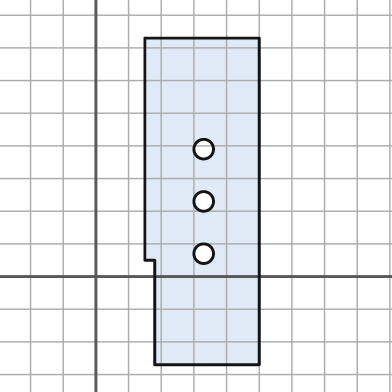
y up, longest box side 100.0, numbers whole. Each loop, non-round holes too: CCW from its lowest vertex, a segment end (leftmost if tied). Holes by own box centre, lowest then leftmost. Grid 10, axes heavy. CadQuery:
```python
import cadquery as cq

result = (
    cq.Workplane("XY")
    .moveTo(18.0, -27.0)
    .lineTo(50.0, -27.0)
    .lineTo(50.0, 73.0)
    .lineTo(15.0, 73.0)
    .lineTo(15.0, 5.0)
    .lineTo(18.0, 5.0)
    .close()
    .moveTo(33.0, 7.0)
    .circle(3.0)
    .moveTo(33.0, 23.0)
    .circle(3.0)
    .moveTo(33.0, 39.0)
    .circle(3.0)
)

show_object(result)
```